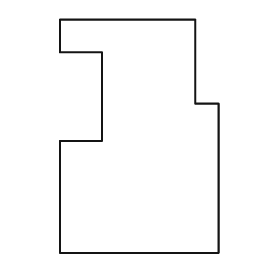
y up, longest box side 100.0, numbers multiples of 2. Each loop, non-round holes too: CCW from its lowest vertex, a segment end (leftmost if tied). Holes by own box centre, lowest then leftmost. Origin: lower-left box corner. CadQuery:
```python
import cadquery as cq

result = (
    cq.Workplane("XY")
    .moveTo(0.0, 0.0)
    .lineTo(68.0, 0.0)
    .lineTo(68.0, 64.0)
    .lineTo(58.0, 64.0)
    .lineTo(58.0, 100.0)
    .lineTo(0.0, 100.0)
    .lineTo(0.0, 86.0)
    .lineTo(18.0, 86.0)
    .lineTo(18.0, 48.0)
    .lineTo(0.0, 48.0)
    .close()
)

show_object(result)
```